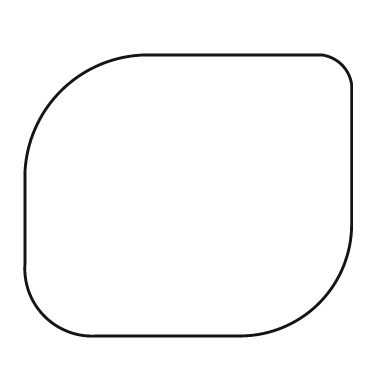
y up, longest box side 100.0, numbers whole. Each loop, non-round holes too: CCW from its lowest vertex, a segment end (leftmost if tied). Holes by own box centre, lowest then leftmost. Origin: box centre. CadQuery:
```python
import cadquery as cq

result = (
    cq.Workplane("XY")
    .moveTo(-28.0, -43.0)
    .lineTo(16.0, -43.0)
    .threePointArc((40.0, -33.0), (50.0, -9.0))
    .lineTo(50.0, 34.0)
    .threePointArc((47.0, 40.0), (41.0, 43.0))
    .lineTo(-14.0, 43.0)
    .threePointArc((-39.0, 32.0), (-50.0, 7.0))
    .lineTo(-50.0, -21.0)
    .threePointArc((-44.0, -37.0), (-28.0, -43.0))
    .close()
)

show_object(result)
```